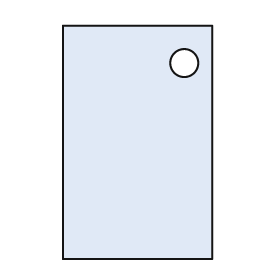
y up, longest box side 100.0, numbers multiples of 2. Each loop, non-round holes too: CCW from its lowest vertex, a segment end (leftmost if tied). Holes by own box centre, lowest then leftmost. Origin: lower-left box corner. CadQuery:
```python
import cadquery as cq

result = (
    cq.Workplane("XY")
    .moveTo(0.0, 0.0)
    .lineTo(64.0, 0.0)
    .lineTo(64.0, 100.0)
    .lineTo(0.0, 100.0)
    .close()
    .moveTo(52.0, 84.0)
    .circle(6.0)
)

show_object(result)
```